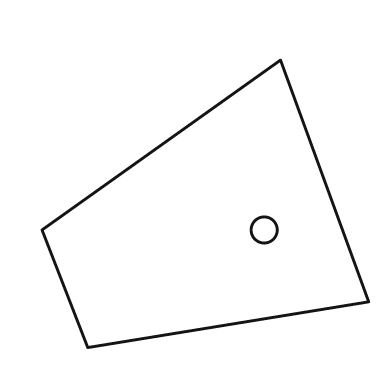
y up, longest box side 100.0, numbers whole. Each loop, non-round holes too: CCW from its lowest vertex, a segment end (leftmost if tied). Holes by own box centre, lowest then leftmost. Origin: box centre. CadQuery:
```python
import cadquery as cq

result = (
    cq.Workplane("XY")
    .moveTo(-36.0, -44.0)
    .lineTo(50.0, -30.0)
    .lineTo(23.0, 44.0)
    .lineTo(-50.0, -8.0)
    .close()
    .moveTo(18.0, -8.0)
    .circle(4.0)
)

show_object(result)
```